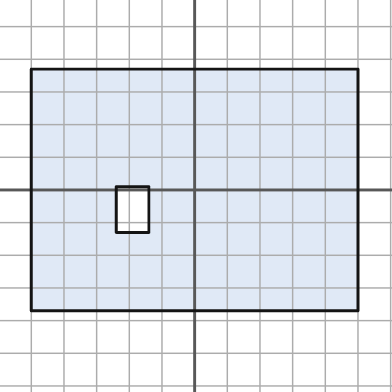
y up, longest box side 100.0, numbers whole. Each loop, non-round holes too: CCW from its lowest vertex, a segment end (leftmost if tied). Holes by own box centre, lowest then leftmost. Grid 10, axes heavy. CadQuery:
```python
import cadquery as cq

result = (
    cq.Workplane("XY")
    .moveTo(-50.0, -37.0)
    .lineTo(50.0, -37.0)
    .lineTo(50.0, 37.0)
    .lineTo(-50.0, 37.0)
    .close()
    .moveTo(-24.0, -13.0)
    .lineTo(-14.0, -13.0)
    .lineTo(-14.0, 1.0)
    .lineTo(-24.0, 1.0)
    .close()
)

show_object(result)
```